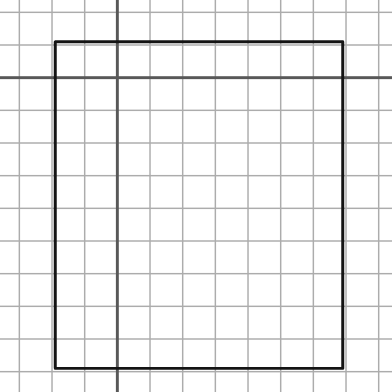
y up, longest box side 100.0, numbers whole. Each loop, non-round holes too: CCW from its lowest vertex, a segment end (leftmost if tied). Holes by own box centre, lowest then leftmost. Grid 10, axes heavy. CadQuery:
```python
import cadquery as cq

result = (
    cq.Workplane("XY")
    .moveTo(-19.0, -89.0)
    .lineTo(69.0, -89.0)
    .lineTo(69.0, 11.0)
    .lineTo(-19.0, 11.0)
    .close()
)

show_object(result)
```